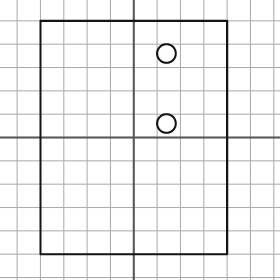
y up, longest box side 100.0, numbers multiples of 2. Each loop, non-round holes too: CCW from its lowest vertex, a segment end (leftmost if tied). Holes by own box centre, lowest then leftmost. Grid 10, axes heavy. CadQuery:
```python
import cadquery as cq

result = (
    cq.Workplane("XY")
    .moveTo(-40.0, -50.0)
    .lineTo(40.0, -50.0)
    .lineTo(40.0, 50.0)
    .lineTo(-40.0, 50.0)
    .close()
    .moveTo(14.0, 6.0)
    .circle(4.0)
    .moveTo(14.0, 36.0)
    .circle(4.0)
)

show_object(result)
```